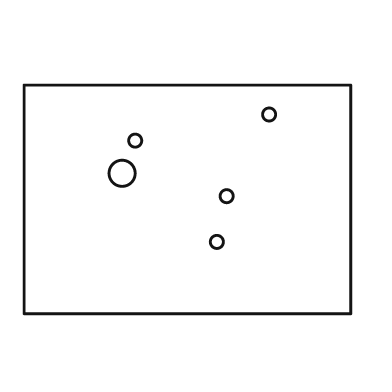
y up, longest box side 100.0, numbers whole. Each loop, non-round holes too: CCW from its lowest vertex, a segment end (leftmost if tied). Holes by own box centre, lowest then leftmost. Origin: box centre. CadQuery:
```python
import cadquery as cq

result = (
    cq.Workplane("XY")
    .moveTo(-50.0, -35.0)
    .lineTo(50.0, -35.0)
    .lineTo(50.0, 35.0)
    .lineTo(-50.0, 35.0)
    .close()
    .moveTo(9.0, -13.0)
    .circle(2.0)
    .moveTo(12.0, 1.0)
    .circle(2.0)
    .moveTo(-20.0, 8.0)
    .circle(4.0)
    .moveTo(-16.0, 18.0)
    .circle(2.0)
    .moveTo(25.0, 26.0)
    .circle(2.0)
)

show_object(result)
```